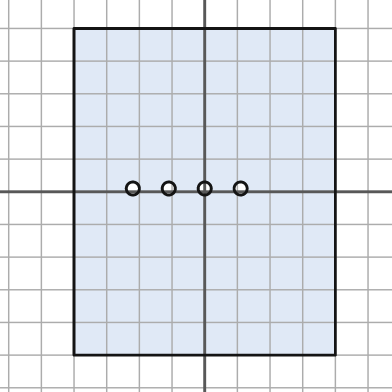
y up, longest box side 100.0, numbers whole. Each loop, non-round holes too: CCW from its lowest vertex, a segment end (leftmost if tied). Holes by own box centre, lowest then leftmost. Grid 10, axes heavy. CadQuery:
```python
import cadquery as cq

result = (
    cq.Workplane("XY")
    .moveTo(-40.0, -50.0)
    .lineTo(40.0, -50.0)
    .lineTo(40.0, 50.0)
    .lineTo(-40.0, 50.0)
    .close()
    .moveTo(-22.0, 1.0)
    .circle(2.0)
    .moveTo(-11.0, 1.0)
    .circle(2.0)
    .moveTo(0.0, 1.0)
    .circle(2.0)
    .moveTo(11.0, 1.0)
    .circle(2.0)
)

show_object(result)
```